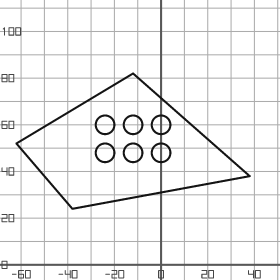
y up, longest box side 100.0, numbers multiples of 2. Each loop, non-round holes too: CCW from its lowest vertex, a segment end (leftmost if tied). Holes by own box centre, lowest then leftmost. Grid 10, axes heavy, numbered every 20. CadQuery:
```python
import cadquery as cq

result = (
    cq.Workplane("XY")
    .moveTo(-38.0, 24.0)
    .lineTo(38.0, 38.0)
    .lineTo(-12.0, 82.0)
    .lineTo(-62.0, 52.0)
    .close()
    .moveTo(-24.0, 48.0)
    .circle(4.0)
    .moveTo(-12.0, 48.0)
    .circle(4.0)
    .moveTo(0.0, 48.0)
    .circle(4.0)
    .moveTo(-24.0, 60.0)
    .circle(4.0)
    .moveTo(-12.0, 60.0)
    .circle(4.0)
    .moveTo(0.0, 60.0)
    .circle(4.0)
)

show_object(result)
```